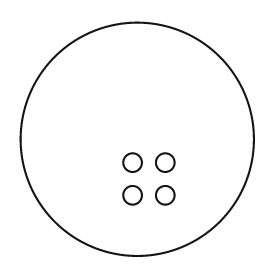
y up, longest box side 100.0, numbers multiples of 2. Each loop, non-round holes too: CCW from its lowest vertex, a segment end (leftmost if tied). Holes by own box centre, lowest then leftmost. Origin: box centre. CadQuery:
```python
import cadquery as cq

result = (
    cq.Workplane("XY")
    .moveTo(0.0, 0.0)
    .circle(50.0)
    .moveTo(-2.0, -24.0)
    .circle(4.0)
    .moveTo(12.0, -24.0)
    .circle(4.0)
    .moveTo(-2.0, -10.0)
    .circle(4.0)
    .moveTo(12.0, -10.0)
    .circle(4.0)
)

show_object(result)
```